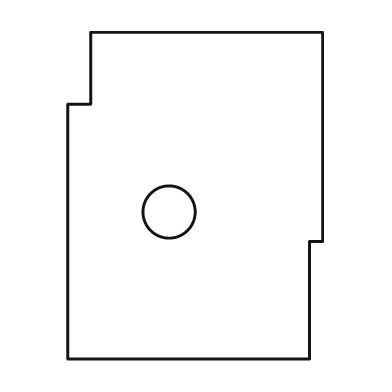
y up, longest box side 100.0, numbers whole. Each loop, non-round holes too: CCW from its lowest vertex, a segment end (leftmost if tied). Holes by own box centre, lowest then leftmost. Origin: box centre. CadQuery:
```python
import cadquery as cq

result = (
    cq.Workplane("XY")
    .moveTo(-39.0, -50.0)
    .lineTo(35.0, -50.0)
    .lineTo(35.0, -14.0)
    .lineTo(39.0, -14.0)
    .lineTo(39.0, 50.0)
    .lineTo(-32.0, 50.0)
    .lineTo(-32.0, 28.0)
    .lineTo(-39.0, 28.0)
    .close()
    .moveTo(-8.0, -5.0)
    .circle(8.0)
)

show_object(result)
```